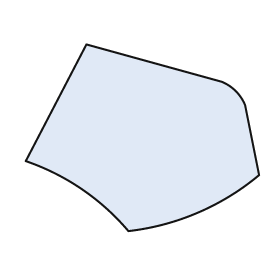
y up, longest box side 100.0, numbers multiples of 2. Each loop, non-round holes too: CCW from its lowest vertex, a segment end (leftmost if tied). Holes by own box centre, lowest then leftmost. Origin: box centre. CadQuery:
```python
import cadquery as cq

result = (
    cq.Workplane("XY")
    .moveTo(-6.0, -40.0)
    .threePointArc((24.0, -32.0), (50.0, -16.0))
    .lineTo(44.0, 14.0)
    .threePointArc((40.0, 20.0), (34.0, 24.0))
    .lineTo(-24.0, 40.0)
    .lineTo(-50.0, -10.0)
    .threePointArc((-26.0, -22.0), (-6.0, -40.0))
    .close()
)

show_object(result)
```